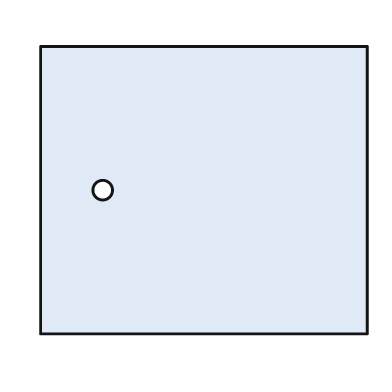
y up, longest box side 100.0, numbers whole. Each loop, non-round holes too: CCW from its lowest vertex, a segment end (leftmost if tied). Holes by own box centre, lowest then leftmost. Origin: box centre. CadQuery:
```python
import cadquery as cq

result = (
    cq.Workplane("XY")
    .moveTo(-50.0, -44.0)
    .lineTo(50.0, -44.0)
    .lineTo(50.0, 44.0)
    .lineTo(-50.0, 44.0)
    .close()
    .moveTo(-31.0, 0.0)
    .circle(3.0)
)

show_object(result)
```